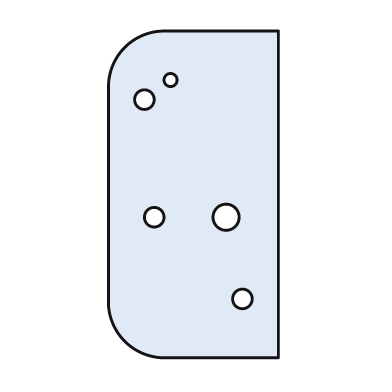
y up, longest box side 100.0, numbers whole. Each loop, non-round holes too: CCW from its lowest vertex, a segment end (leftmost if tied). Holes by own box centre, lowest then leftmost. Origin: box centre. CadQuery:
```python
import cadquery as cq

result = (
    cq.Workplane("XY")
    .moveTo(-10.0, -50.0)
    .lineTo(26.0, -50.0)
    .lineTo(26.0, 50.0)
    .lineTo(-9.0, 50.0)
    .threePointArc((-21.0, 45.0), (-26.0, 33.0))
    .lineTo(-26.0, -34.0)
    .threePointArc((-21.0, -45.0), (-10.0, -50.0))
    .close()
    .moveTo(15.0, -32.0)
    .circle(3.0)
    .moveTo(-12.0, -7.0)
    .circle(3.0)
    .moveTo(10.0, -7.0)
    .circle(4.0)
    .moveTo(-15.0, 29.0)
    .circle(3.0)
    .moveTo(-7.0, 35.0)
    .circle(2.0)
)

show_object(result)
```